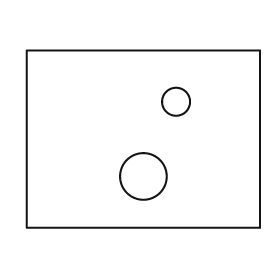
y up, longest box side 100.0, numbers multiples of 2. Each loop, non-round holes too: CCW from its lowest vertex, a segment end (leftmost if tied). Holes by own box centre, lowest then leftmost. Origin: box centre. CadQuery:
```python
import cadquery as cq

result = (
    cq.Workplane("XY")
    .moveTo(-50.0, -38.0)
    .lineTo(50.0, -38.0)
    .lineTo(50.0, 38.0)
    .lineTo(-50.0, 38.0)
    .close()
    .moveTo(0.0, -16.0)
    .circle(10.0)
    .moveTo(14.0, 16.0)
    .circle(6.0)
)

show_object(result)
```